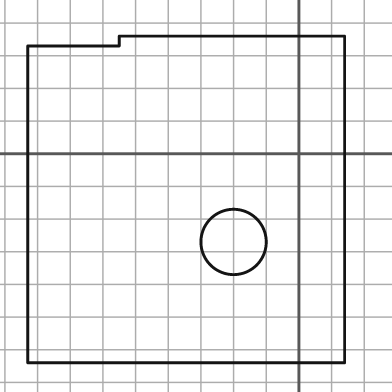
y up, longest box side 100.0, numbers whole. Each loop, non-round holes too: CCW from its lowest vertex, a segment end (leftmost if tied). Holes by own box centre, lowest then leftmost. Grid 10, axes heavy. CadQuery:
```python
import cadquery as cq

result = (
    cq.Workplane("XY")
    .moveTo(-83.0, -64.0)
    .lineTo(14.0, -64.0)
    .lineTo(14.0, 36.0)
    .lineTo(-55.0, 36.0)
    .lineTo(-55.0, 33.0)
    .lineTo(-83.0, 33.0)
    .close()
    .moveTo(-20.0, -27.0)
    .circle(10.0)
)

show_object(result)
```